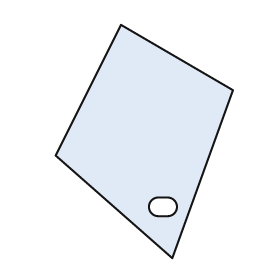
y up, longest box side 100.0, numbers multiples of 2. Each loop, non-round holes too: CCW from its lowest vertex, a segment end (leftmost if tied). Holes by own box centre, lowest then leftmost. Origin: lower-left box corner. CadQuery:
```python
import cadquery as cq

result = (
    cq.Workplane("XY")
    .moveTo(50.0, 0.0)
    .lineTo(76.0, 72.0)
    .lineTo(28.0, 100.0)
    .lineTo(0.0, 44.0)
    .close()
    .moveTo(44.0, 18.0)
    .lineTo(48.0, 18.0)
    .threePointArc((52.0, 22.0), (48.0, 26.0))
    .lineTo(44.0, 26.0)
    .threePointArc((40.0, 22.0), (44.0, 18.0))
    .close()
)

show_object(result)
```